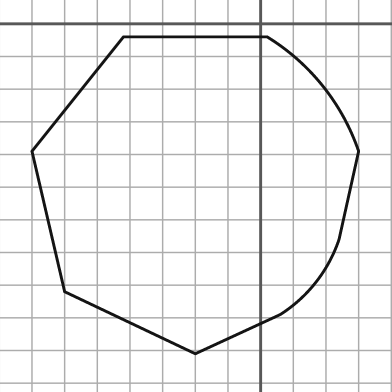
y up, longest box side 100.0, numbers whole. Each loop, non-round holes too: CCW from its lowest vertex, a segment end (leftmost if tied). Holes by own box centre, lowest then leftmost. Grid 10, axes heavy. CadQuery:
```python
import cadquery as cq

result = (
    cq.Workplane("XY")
    .moveTo(-20.0, -101.0)
    .lineTo(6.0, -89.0)
    .threePointArc((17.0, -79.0), (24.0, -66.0))
    .lineTo(30.0, -39.0)
    .threePointArc((19.0, -19.0), (2.0, -4.0))
    .lineTo(-42.0, -4.0)
    .lineTo(-70.0, -39.0)
    .lineTo(-60.0, -82.0)
    .close()
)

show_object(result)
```